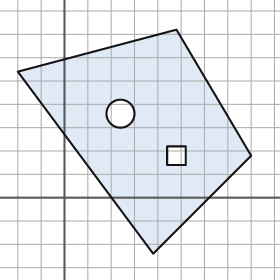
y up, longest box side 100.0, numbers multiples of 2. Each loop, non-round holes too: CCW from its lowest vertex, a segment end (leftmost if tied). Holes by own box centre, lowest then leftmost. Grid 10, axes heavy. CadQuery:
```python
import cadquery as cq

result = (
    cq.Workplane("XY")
    .moveTo(38.0, -24.0)
    .lineTo(80.0, 18.0)
    .lineTo(48.0, 72.0)
    .lineTo(-20.0, 54.0)
    .close()
    .moveTo(44.0, 14.0)
    .lineTo(52.0, 14.0)
    .lineTo(52.0, 22.0)
    .lineTo(44.0, 22.0)
    .close()
    .moveTo(24.0, 36.0)
    .circle(6.0)
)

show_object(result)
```